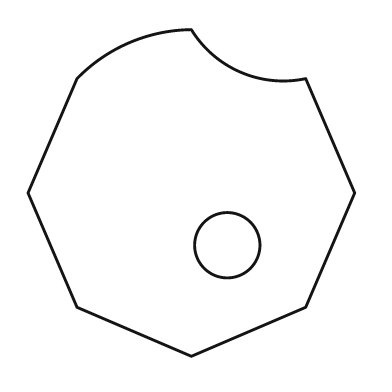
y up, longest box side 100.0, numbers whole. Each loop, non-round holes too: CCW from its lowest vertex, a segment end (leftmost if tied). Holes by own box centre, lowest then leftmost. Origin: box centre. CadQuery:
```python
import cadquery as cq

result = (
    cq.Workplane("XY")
    .moveTo(0.0, -50.0)
    .lineTo(35.0, -35.0)
    .lineTo(50.0, 0.0)
    .lineTo(35.0, 35.0)
    .threePointArc((15.0, 37.0), (0.0, 50.0))
    .threePointArc((-19.0, 46.0), (-35.0, 35.0))
    .lineTo(-50.0, 0.0)
    .lineTo(-35.0, -35.0)
    .close()
    .moveTo(11.0, -16.0)
    .circle(10.0)
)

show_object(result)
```